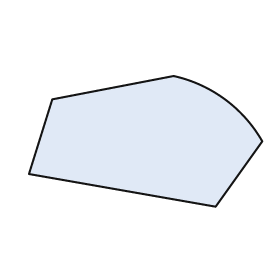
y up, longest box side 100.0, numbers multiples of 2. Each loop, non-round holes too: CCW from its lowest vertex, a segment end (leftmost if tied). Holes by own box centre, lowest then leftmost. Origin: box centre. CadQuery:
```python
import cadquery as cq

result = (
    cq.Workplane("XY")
    .moveTo(30.0, -28.0)
    .lineTo(50.0, 0.0)
    .threePointArc((34.0, 18.0), (12.0, 28.0))
    .lineTo(-40.0, 18.0)
    .lineTo(-50.0, -14.0)
    .close()
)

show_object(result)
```